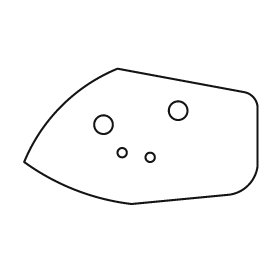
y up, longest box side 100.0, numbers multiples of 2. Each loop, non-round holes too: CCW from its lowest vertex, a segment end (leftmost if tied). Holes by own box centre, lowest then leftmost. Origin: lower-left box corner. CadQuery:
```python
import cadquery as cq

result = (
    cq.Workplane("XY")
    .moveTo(46.0, 0.0)
    .lineTo(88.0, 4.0)
    .threePointArc((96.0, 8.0), (100.0, 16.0))
    .lineTo(100.0, 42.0)
    .threePointArc((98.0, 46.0), (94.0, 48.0))
    .lineTo(40.0, 58.0)
    .threePointArc((16.0, 42.0), (0.0, 18.0))
    .threePointArc((22.0, 6.0), (46.0, 0.0))
    .close()
    .moveTo(54.0, 20.0)
    .circle(2.0)
    .moveTo(42.0, 22.0)
    .circle(2.0)
    .moveTo(34.0, 34.0)
    .circle(4.0)
    .moveTo(66.0, 40.0)
    .circle(4.0)
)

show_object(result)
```